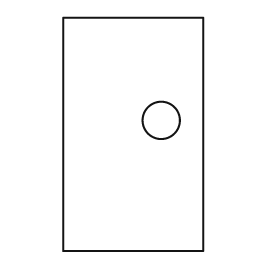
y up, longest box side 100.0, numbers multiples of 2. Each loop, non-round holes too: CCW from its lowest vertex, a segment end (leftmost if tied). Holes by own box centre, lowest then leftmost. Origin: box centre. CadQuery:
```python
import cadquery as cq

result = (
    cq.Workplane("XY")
    .moveTo(-30.0, -50.0)
    .lineTo(30.0, -50.0)
    .lineTo(30.0, 50.0)
    .lineTo(-30.0, 50.0)
    .close()
    .moveTo(12.0, 6.0)
    .circle(8.0)
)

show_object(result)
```